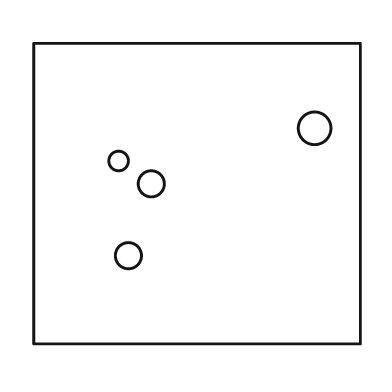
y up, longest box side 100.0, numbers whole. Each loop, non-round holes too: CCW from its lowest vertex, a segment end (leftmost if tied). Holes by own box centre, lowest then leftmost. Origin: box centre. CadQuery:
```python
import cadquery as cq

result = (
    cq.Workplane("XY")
    .moveTo(-50.0, -46.0)
    .lineTo(50.0, -46.0)
    .lineTo(50.0, 46.0)
    .lineTo(-50.0, 46.0)
    .close()
    .moveTo(-21.0, -19.0)
    .circle(4.0)
    .moveTo(-14.0, 3.0)
    .circle(4.0)
    .moveTo(-24.0, 10.0)
    .circle(3.0)
    .moveTo(36.0, 20.0)
    .circle(5.0)
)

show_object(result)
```